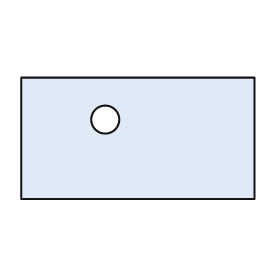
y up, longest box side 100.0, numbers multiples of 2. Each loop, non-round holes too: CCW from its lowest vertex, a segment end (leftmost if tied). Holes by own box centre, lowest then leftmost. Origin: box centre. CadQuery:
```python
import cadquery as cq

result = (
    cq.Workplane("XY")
    .moveTo(-50.0, -26.0)
    .lineTo(50.0, -26.0)
    .lineTo(50.0, 26.0)
    .lineTo(-50.0, 26.0)
    .close()
    .moveTo(-14.0, 8.0)
    .circle(6.0)
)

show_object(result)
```